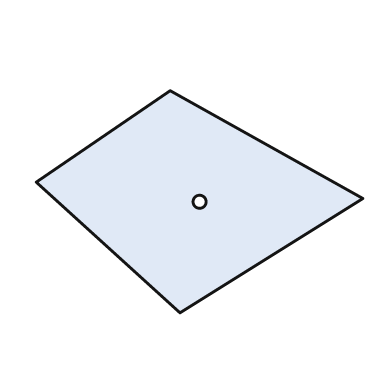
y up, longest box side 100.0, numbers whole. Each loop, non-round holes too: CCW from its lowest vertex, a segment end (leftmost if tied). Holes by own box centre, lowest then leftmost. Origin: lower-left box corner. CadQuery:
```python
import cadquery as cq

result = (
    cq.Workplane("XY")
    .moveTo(44.0, 0.0)
    .lineTo(100.0, 35.0)
    .lineTo(41.0, 68.0)
    .lineTo(0.0, 40.0)
    .close()
    .moveTo(50.0, 34.0)
    .circle(2.0)
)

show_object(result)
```